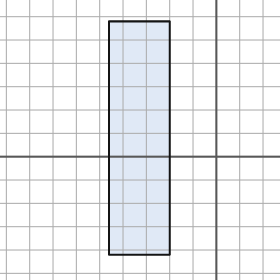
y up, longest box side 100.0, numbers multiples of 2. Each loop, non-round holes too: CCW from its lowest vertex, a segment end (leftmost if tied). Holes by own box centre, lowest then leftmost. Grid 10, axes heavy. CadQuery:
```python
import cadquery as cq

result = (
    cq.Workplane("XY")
    .moveTo(-46.0, -42.0)
    .lineTo(-20.0, -42.0)
    .lineTo(-20.0, 58.0)
    .lineTo(-46.0, 58.0)
    .close()
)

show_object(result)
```